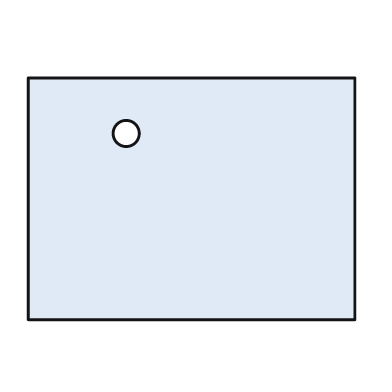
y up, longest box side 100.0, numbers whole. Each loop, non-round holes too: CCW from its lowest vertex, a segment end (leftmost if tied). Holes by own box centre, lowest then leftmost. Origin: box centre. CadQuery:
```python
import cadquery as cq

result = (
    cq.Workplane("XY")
    .moveTo(-50.0, -37.0)
    .lineTo(50.0, -37.0)
    .lineTo(50.0, 37.0)
    .lineTo(-50.0, 37.0)
    .close()
    .moveTo(-20.0, 20.0)
    .circle(4.0)
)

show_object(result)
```